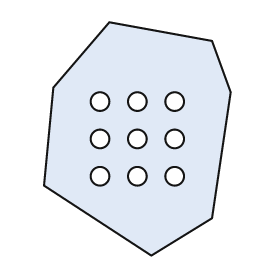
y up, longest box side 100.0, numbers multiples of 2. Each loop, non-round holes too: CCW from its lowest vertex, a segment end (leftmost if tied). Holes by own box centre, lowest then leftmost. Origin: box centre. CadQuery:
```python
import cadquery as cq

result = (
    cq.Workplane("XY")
    .moveTo(6.0, -50.0)
    .lineTo(32.0, -34.0)
    .lineTo(40.0, 20.0)
    .lineTo(32.0, 42.0)
    .lineTo(-12.0, 50.0)
    .lineTo(-36.0, 22.0)
    .lineTo(-40.0, -20.0)
    .close()
    .moveTo(-16.0, -16.0)
    .circle(4.0)
    .moveTo(0.0, -16.0)
    .circle(4.0)
    .moveTo(16.0, -16.0)
    .circle(4.0)
    .moveTo(-16.0, 0.0)
    .circle(4.0)
    .moveTo(0.0, 0.0)
    .circle(4.0)
    .moveTo(16.0, 0.0)
    .circle(4.0)
    .moveTo(-16.0, 16.0)
    .circle(4.0)
    .moveTo(0.0, 16.0)
    .circle(4.0)
    .moveTo(16.0, 16.0)
    .circle(4.0)
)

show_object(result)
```